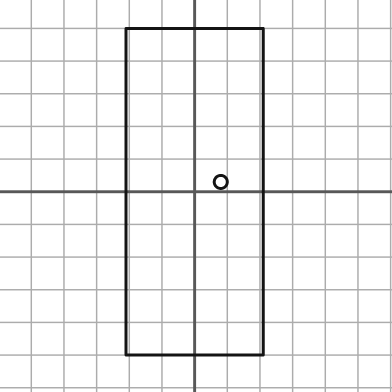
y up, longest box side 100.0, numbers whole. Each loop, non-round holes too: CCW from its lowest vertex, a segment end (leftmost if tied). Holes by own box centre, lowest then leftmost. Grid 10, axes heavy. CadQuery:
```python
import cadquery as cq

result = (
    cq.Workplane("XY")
    .moveTo(-21.0, -50.0)
    .lineTo(21.0, -50.0)
    .lineTo(21.0, 50.0)
    .lineTo(-21.0, 50.0)
    .close()
    .moveTo(8.0, 3.0)
    .circle(2.0)
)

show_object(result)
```